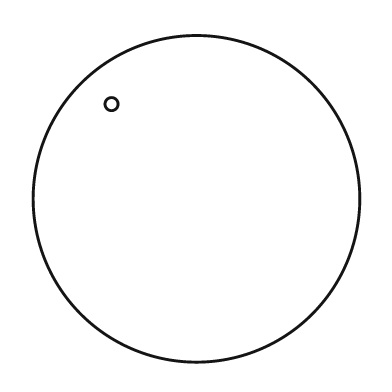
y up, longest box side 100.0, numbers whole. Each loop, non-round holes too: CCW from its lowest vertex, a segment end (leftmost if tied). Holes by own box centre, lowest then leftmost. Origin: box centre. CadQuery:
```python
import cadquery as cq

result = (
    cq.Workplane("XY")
    .moveTo(0.0, 0.0)
    .circle(50.0)
    .moveTo(-26.0, 29.0)
    .circle(2.0)
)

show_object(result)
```